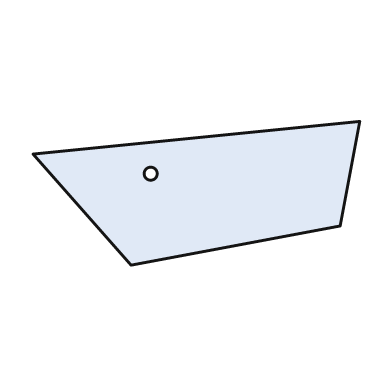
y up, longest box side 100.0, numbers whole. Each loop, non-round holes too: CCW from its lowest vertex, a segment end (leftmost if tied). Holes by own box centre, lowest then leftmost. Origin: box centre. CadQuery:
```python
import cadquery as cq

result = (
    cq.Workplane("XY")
    .moveTo(-20.0, -22.0)
    .lineTo(44.0, -10.0)
    .lineTo(50.0, 22.0)
    .lineTo(-50.0, 12.0)
    .close()
    .moveTo(-14.0, 6.0)
    .circle(2.0)
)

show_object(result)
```